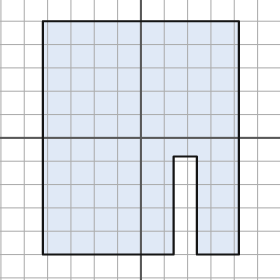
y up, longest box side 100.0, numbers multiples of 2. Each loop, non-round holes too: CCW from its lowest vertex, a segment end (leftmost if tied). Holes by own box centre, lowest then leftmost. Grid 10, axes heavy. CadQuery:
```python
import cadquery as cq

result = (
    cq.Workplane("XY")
    .moveTo(-42.0, -50.0)
    .lineTo(14.0, -50.0)
    .lineTo(14.0, -8.0)
    .lineTo(24.0, -8.0)
    .lineTo(24.0, -50.0)
    .lineTo(42.0, -50.0)
    .lineTo(42.0, 50.0)
    .lineTo(-42.0, 50.0)
    .close()
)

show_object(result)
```